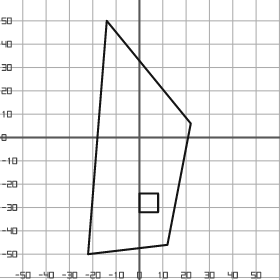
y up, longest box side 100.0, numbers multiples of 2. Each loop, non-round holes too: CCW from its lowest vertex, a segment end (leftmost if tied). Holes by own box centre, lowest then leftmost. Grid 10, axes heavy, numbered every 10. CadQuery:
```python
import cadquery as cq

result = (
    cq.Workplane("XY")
    .moveTo(-22.0, -50.0)
    .lineTo(12.0, -46.0)
    .lineTo(22.0, 6.0)
    .lineTo(-14.0, 50.0)
    .close()
    .moveTo(0.0, -32.0)
    .lineTo(8.0, -32.0)
    .lineTo(8.0, -24.0)
    .lineTo(0.0, -24.0)
    .close()
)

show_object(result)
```